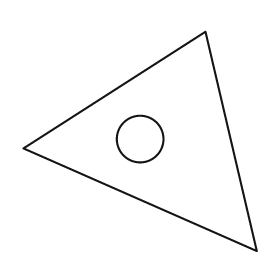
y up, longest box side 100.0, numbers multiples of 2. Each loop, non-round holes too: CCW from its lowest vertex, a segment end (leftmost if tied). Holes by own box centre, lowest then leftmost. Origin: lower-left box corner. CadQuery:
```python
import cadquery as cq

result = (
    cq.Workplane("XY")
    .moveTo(100.0, 0.0)
    .lineTo(78.0, 94.0)
    .lineTo(0.0, 44.0)
    .close()
    .moveTo(50.0, 48.0)
    .circle(10.0)
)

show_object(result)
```